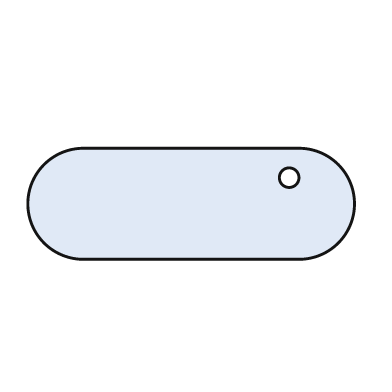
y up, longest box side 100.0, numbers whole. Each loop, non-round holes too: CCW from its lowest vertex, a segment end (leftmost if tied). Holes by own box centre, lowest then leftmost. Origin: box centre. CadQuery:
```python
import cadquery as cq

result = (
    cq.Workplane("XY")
    .moveTo(-33.0, -17.0)
    .lineTo(33.0, -17.0)
    .threePointArc((50.0, 0.0), (33.0, 17.0))
    .lineTo(-33.0, 17.0)
    .threePointArc((-50.0, 0.0), (-33.0, -17.0))
    .close()
    .moveTo(30.0, 8.0)
    .circle(3.0)
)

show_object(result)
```